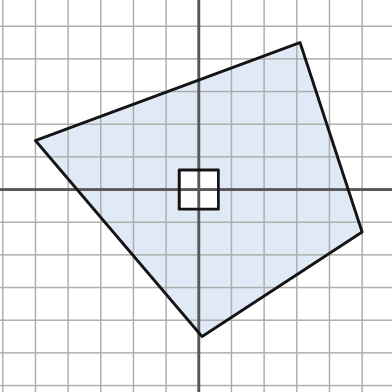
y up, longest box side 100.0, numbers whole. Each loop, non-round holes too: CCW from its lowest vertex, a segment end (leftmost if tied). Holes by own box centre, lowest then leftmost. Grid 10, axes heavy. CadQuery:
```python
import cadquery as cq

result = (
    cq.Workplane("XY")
    .moveTo(1.0, -45.0)
    .lineTo(50.0, -13.0)
    .lineTo(31.0, 45.0)
    .lineTo(-50.0, 15.0)
    .close()
    .moveTo(-6.0, -6.0)
    .lineTo(6.0, -6.0)
    .lineTo(6.0, 6.0)
    .lineTo(-6.0, 6.0)
    .close()
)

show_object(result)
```